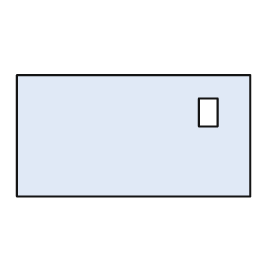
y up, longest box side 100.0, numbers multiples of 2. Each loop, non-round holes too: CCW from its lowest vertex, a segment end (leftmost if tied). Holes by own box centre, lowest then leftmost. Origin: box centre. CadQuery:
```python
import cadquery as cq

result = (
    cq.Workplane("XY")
    .moveTo(-50.0, -26.0)
    .lineTo(50.0, -26.0)
    .lineTo(50.0, 26.0)
    .lineTo(-50.0, 26.0)
    .close()
    .moveTo(28.0, 4.0)
    .lineTo(36.0, 4.0)
    .lineTo(36.0, 16.0)
    .lineTo(28.0, 16.0)
    .close()
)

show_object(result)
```